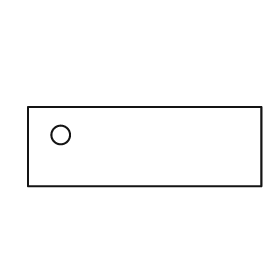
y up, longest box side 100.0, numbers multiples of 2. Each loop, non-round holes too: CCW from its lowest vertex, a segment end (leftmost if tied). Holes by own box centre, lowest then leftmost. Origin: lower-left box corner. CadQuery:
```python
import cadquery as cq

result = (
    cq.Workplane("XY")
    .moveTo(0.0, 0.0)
    .lineTo(100.0, 0.0)
    .lineTo(100.0, 34.0)
    .lineTo(0.0, 34.0)
    .close()
    .moveTo(14.0, 22.0)
    .circle(4.0)
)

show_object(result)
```